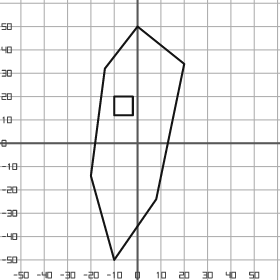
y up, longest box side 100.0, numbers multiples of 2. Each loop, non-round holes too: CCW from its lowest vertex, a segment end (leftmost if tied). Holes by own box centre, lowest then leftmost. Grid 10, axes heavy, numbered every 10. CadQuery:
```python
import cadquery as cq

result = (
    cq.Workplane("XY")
    .moveTo(-10.0, -50.0)
    .lineTo(8.0, -24.0)
    .lineTo(20.0, 34.0)
    .lineTo(0.0, 50.0)
    .lineTo(-14.0, 32.0)
    .lineTo(-20.0, -14.0)
    .close()
    .moveTo(-10.0, 12.0)
    .lineTo(-2.0, 12.0)
    .lineTo(-2.0, 20.0)
    .lineTo(-10.0, 20.0)
    .close()
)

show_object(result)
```